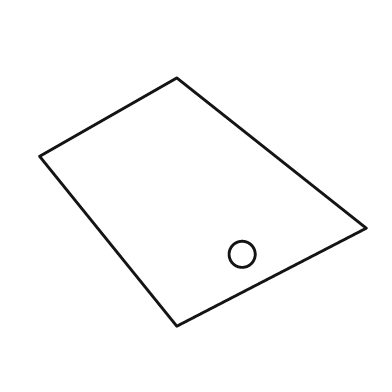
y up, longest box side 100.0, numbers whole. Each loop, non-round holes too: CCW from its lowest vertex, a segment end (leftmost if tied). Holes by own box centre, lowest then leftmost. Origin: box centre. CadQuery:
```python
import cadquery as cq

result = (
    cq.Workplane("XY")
    .moveTo(-8.0, -38.0)
    .lineTo(50.0, -8.0)
    .lineTo(-8.0, 38.0)
    .lineTo(-50.0, 14.0)
    .close()
    .moveTo(12.0, -16.0)
    .circle(4.0)
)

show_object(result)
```